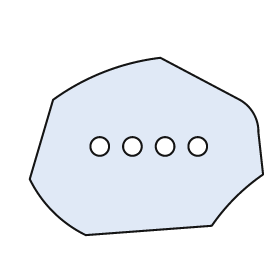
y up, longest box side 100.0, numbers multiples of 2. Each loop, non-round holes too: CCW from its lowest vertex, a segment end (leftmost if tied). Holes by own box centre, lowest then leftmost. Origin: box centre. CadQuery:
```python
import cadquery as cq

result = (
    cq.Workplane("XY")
    .moveTo(-26.0, -38.0)
    .lineTo(28.0, -34.0)
    .threePointArc((38.0, -22.0), (50.0, -12.0))
    .lineTo(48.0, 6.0)
    .threePointArc((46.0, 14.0), (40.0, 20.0))
    .lineTo(6.0, 38.0)
    .threePointArc((-18.0, 32.0), (-40.0, 20.0))
    .lineTo(-50.0, -14.0)
    .threePointArc((-40.0, -28.0), (-26.0, -38.0))
    .close()
    .moveTo(-20.0, 0.0)
    .circle(4.0)
    .moveTo(-6.0, 0.0)
    .circle(4.0)
    .moveTo(8.0, 0.0)
    .circle(4.0)
    .moveTo(22.0, 0.0)
    .circle(4.0)
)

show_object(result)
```